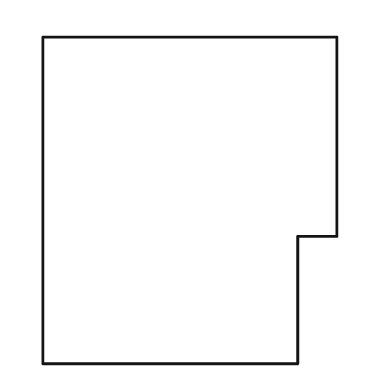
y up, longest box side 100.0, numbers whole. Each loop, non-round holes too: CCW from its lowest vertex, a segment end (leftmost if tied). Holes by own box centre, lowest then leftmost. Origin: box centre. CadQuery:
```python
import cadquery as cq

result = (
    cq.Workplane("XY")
    .moveTo(-45.0, -50.0)
    .lineTo(33.0, -50.0)
    .lineTo(33.0, -11.0)
    .lineTo(45.0, -11.0)
    .lineTo(45.0, 50.0)
    .lineTo(-45.0, 50.0)
    .close()
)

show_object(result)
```